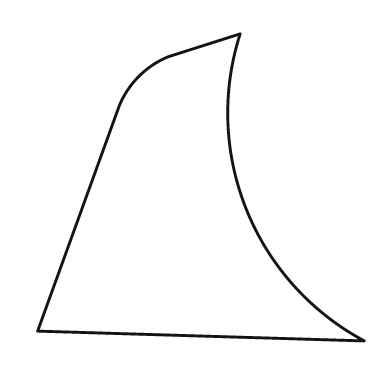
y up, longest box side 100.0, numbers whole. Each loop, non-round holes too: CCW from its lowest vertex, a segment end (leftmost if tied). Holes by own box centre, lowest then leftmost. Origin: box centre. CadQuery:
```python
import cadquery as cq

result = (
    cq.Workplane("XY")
    .moveTo(50.0, -47.0)
    .threePointArc((14.0, -7.0), (12.0, 47.0))
    .lineTo(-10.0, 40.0)
    .threePointArc((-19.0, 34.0), (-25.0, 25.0))
    .lineTo(-50.0, -44.0)
    .close()
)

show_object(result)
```